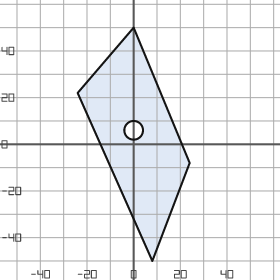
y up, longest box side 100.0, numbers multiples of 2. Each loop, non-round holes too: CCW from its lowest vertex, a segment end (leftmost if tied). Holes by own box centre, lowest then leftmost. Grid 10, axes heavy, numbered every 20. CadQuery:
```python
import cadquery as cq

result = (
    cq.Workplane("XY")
    .moveTo(8.0, -50.0)
    .lineTo(24.0, -8.0)
    .lineTo(0.0, 50.0)
    .lineTo(-24.0, 22.0)
    .close()
    .moveTo(0.0, 6.0)
    .circle(4.0)
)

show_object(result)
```